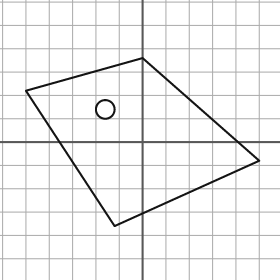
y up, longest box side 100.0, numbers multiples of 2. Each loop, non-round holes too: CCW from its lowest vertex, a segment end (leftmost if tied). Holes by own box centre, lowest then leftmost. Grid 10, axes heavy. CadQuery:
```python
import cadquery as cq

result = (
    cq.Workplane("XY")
    .moveTo(-12.0, -36.0)
    .lineTo(50.0, -8.0)
    .lineTo(0.0, 36.0)
    .lineTo(-50.0, 22.0)
    .close()
    .moveTo(-16.0, 14.0)
    .circle(4.0)
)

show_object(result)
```